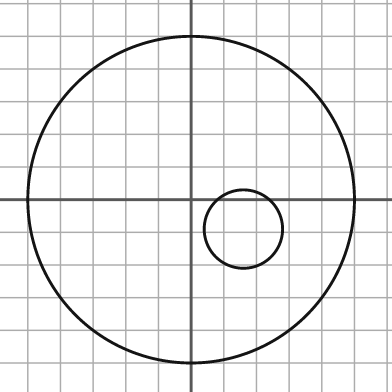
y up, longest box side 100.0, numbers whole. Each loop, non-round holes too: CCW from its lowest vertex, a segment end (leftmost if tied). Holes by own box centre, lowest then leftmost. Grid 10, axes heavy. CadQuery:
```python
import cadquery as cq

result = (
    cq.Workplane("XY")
    .moveTo(0.0, 0.0)
    .circle(50.0)
    .moveTo(16.0, -9.0)
    .circle(12.0)
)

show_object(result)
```